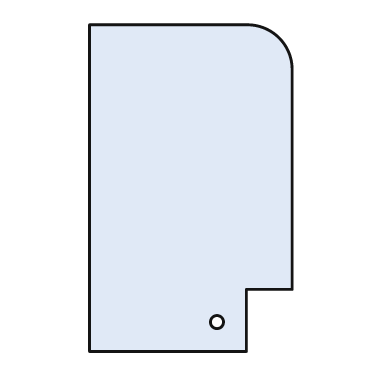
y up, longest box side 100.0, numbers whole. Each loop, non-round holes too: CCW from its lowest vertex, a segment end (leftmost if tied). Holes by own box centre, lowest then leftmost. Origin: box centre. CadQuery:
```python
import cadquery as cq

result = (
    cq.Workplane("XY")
    .moveTo(-31.0, -50.0)
    .lineTo(17.0, -50.0)
    .lineTo(17.0, -31.0)
    .lineTo(31.0, -31.0)
    .lineTo(31.0, 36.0)
    .threePointArc((27.0, 46.0), (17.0, 50.0))
    .lineTo(-31.0, 50.0)
    .close()
    .moveTo(8.0, -41.0)
    .circle(2.0)
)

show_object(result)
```